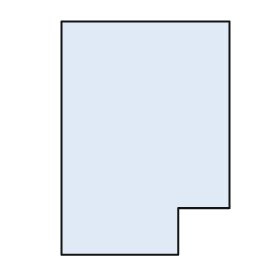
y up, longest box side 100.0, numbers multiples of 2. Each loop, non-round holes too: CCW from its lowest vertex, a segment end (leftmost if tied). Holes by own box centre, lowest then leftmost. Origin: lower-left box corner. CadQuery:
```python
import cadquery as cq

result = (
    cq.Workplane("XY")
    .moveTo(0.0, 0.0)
    .lineTo(50.0, 0.0)
    .lineTo(50.0, 20.0)
    .lineTo(72.0, 20.0)
    .lineTo(72.0, 100.0)
    .lineTo(0.0, 100.0)
    .close()
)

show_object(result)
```